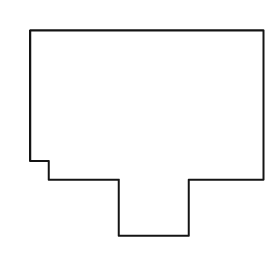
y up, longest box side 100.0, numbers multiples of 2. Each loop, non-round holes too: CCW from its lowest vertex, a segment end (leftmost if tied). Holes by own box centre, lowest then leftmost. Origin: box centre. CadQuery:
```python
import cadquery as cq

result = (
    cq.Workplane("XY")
    .moveTo(-12.0, -44.0)
    .lineTo(18.0, -44.0)
    .lineTo(18.0, -20.0)
    .lineTo(50.0, -20.0)
    .lineTo(50.0, 44.0)
    .lineTo(-50.0, 44.0)
    .lineTo(-50.0, -12.0)
    .lineTo(-42.0, -12.0)
    .lineTo(-42.0, -20.0)
    .lineTo(-12.0, -20.0)
    .close()
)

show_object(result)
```